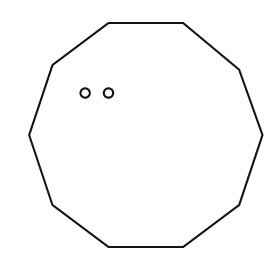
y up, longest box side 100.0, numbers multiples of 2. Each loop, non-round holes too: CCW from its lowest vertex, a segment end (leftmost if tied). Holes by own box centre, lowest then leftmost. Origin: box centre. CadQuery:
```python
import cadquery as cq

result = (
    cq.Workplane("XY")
    .moveTo(-16.0, -48.0)
    .lineTo(16.0, -48.0)
    .lineTo(40.0, -30.0)
    .lineTo(50.0, 0.0)
    .lineTo(40.0, 28.0)
    .lineTo(16.0, 48.0)
    .lineTo(-16.0, 48.0)
    .lineTo(-40.0, 30.0)
    .lineTo(-50.0, 0.0)
    .lineTo(-40.0, -30.0)
    .close()
    .moveTo(-26.0, 18.0)
    .circle(2.0)
    .moveTo(-16.0, 18.0)
    .circle(2.0)
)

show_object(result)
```